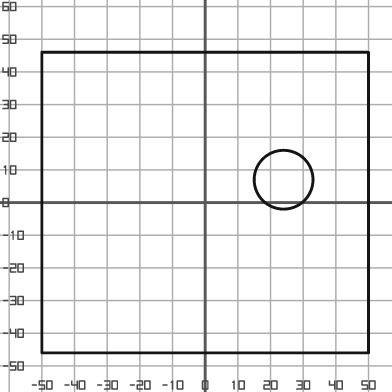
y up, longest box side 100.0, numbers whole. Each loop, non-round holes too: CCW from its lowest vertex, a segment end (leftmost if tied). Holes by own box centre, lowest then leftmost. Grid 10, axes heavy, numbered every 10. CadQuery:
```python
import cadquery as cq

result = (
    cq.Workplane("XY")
    .moveTo(-50.0, -46.0)
    .lineTo(50.0, -46.0)
    .lineTo(50.0, 46.0)
    .lineTo(-50.0, 46.0)
    .close()
    .moveTo(24.0, 7.0)
    .circle(9.0)
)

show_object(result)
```